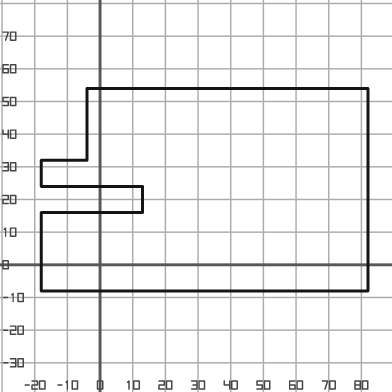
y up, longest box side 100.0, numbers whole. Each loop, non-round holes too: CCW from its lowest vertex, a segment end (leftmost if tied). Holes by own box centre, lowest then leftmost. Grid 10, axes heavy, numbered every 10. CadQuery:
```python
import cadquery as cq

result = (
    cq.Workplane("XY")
    .moveTo(-18.0, -8.0)
    .lineTo(82.0, -8.0)
    .lineTo(82.0, 54.0)
    .lineTo(-4.0, 54.0)
    .lineTo(-4.0, 32.0)
    .lineTo(-18.0, 32.0)
    .lineTo(-18.0, 24.0)
    .lineTo(13.0, 24.0)
    .lineTo(13.0, 16.0)
    .lineTo(-18.0, 16.0)
    .close()
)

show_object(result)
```